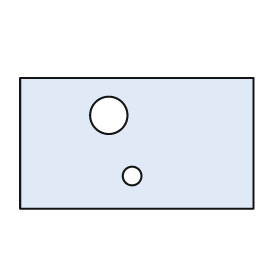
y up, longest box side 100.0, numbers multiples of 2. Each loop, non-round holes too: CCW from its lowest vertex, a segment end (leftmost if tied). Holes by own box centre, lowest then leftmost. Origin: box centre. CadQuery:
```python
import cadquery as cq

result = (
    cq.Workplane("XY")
    .moveTo(-50.0, -28.0)
    .lineTo(50.0, -28.0)
    .lineTo(50.0, 28.0)
    .lineTo(-50.0, 28.0)
    .close()
    .moveTo(-2.0, -14.0)
    .circle(4.0)
    .moveTo(-12.0, 12.0)
    .circle(8.0)
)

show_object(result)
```